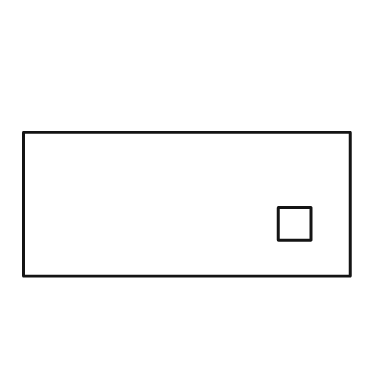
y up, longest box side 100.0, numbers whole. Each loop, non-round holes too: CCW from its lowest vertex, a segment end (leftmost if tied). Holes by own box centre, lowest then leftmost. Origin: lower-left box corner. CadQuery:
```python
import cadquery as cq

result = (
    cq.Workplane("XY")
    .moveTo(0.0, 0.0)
    .lineTo(100.0, 0.0)
    .lineTo(100.0, 44.0)
    .lineTo(0.0, 44.0)
    .close()
    .moveTo(78.0, 11.0)
    .lineTo(88.0, 11.0)
    .lineTo(88.0, 21.0)
    .lineTo(78.0, 21.0)
    .close()
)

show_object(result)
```